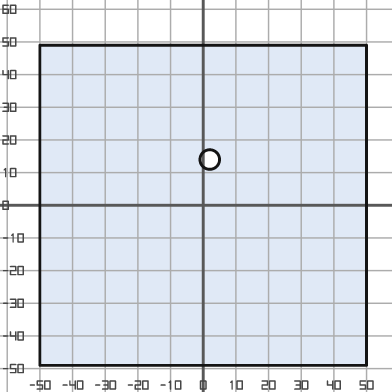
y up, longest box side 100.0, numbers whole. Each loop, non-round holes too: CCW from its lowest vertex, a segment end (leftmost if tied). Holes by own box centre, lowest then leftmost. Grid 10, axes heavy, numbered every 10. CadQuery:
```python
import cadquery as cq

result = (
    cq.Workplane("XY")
    .moveTo(-50.0, -49.0)
    .lineTo(50.0, -49.0)
    .lineTo(50.0, 49.0)
    .lineTo(-50.0, 49.0)
    .close()
    .moveTo(2.0, 14.0)
    .circle(3.0)
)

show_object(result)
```